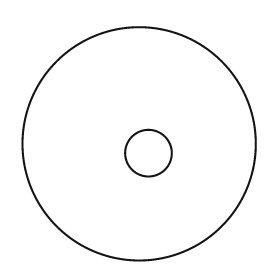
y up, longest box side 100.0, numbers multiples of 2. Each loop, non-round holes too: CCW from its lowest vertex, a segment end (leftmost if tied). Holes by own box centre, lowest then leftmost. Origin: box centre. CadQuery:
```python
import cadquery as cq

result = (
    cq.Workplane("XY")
    .moveTo(0.0, 0.0)
    .circle(50.0)
    .moveTo(4.0, -4.0)
    .circle(10.0)
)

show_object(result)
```